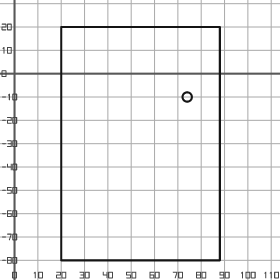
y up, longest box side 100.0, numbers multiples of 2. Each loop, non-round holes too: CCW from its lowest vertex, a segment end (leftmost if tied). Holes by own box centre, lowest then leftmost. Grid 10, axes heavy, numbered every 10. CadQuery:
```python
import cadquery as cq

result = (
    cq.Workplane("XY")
    .moveTo(20.0, -80.0)
    .lineTo(88.0, -80.0)
    .lineTo(88.0, 20.0)
    .lineTo(20.0, 20.0)
    .close()
    .moveTo(74.0, -10.0)
    .circle(2.0)
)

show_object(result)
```